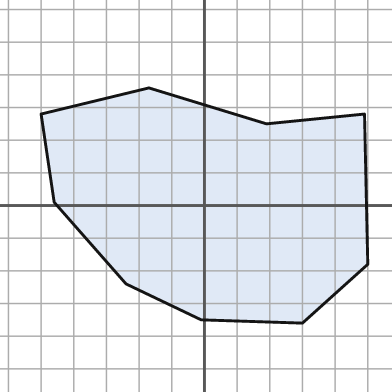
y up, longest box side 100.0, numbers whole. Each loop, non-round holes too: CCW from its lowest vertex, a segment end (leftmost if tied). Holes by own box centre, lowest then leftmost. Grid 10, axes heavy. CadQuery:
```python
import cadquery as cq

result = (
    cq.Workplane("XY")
    .moveTo(30.0, -36.0)
    .lineTo(50.0, -18.0)
    .lineTo(49.0, 28.0)
    .lineTo(19.0, 25.0)
    .lineTo(-17.0, 36.0)
    .lineTo(-50.0, 28.0)
    .lineTo(-46.0, 1.0)
    .lineTo(-24.0, -24.0)
    .lineTo(-1.0, -35.0)
    .close()
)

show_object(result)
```